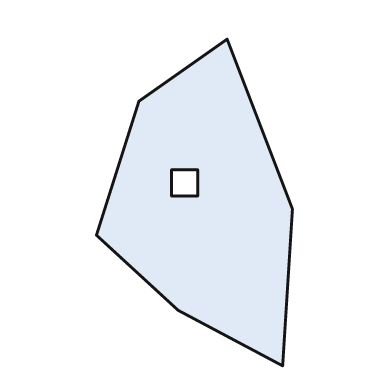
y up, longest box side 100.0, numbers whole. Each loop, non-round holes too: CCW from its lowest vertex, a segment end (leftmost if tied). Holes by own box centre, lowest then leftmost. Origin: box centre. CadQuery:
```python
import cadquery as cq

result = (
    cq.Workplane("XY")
    .moveTo(27.0, -50.0)
    .lineTo(30.0, -2.0)
    .lineTo(10.0, 50.0)
    .lineTo(-17.0, 31.0)
    .lineTo(-30.0, -10.0)
    .lineTo(-5.0, -33.0)
    .close()
    .moveTo(-7.0, 2.0)
    .lineTo(1.0, 2.0)
    .lineTo(1.0, 10.0)
    .lineTo(-7.0, 10.0)
    .close()
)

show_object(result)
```